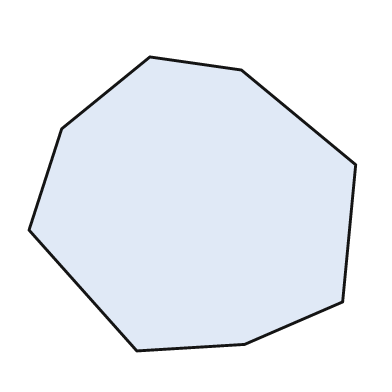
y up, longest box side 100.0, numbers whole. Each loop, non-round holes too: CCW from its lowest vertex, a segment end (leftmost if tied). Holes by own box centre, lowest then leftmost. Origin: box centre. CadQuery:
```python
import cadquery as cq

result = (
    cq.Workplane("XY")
    .moveTo(-17.0, -45.0)
    .lineTo(16.0, -43.0)
    .lineTo(46.0, -30.0)
    .lineTo(50.0, 12.0)
    .lineTo(15.0, 41.0)
    .lineTo(-13.0, 45.0)
    .lineTo(-40.0, 23.0)
    .lineTo(-50.0, -8.0)
    .close()
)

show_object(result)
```